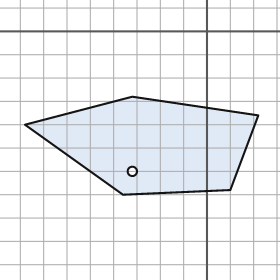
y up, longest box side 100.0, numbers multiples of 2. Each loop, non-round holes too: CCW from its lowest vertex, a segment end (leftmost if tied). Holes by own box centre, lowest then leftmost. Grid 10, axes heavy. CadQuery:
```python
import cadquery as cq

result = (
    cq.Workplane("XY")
    .moveTo(-36.0, -70.0)
    .lineTo(10.0, -68.0)
    .lineTo(22.0, -36.0)
    .lineTo(-32.0, -28.0)
    .lineTo(-78.0, -40.0)
    .close()
    .moveTo(-32.0, -60.0)
    .circle(2.0)
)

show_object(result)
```